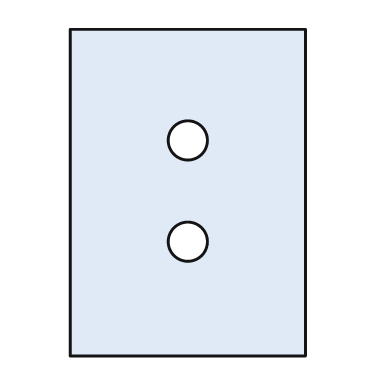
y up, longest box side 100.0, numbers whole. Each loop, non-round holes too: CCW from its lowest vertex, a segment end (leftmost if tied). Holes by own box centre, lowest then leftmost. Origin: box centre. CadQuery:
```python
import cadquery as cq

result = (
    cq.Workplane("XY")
    .moveTo(-36.0, -50.0)
    .lineTo(36.0, -50.0)
    .lineTo(36.0, 50.0)
    .lineTo(-36.0, 50.0)
    .close()
    .moveTo(0.0, -15.0)
    .circle(6.0)
    .moveTo(0.0, 16.0)
    .circle(6.0)
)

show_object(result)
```